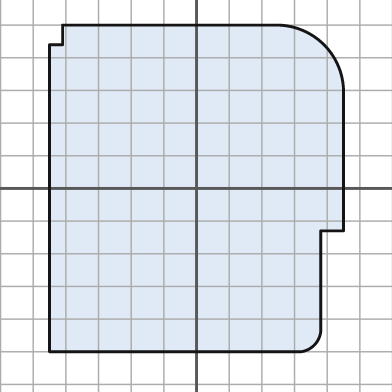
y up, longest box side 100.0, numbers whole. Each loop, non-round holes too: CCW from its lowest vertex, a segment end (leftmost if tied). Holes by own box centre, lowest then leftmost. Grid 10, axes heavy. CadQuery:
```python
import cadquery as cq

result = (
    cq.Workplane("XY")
    .moveTo(-45.0, -50.0)
    .lineTo(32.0, -50.0)
    .threePointArc((36.0, -48.0), (38.0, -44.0))
    .lineTo(38.0, -13.0)
    .lineTo(45.0, -13.0)
    .lineTo(45.0, 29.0)
    .threePointArc((39.0, 44.0), (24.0, 50.0))
    .lineTo(-41.0, 50.0)
    .lineTo(-41.0, 44.0)
    .lineTo(-45.0, 44.0)
    .close()
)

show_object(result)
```